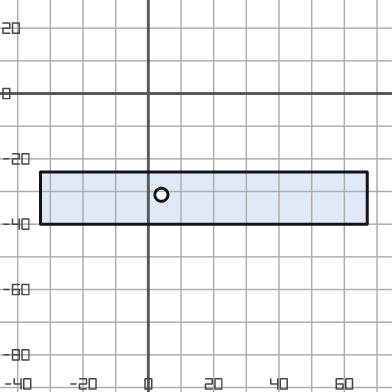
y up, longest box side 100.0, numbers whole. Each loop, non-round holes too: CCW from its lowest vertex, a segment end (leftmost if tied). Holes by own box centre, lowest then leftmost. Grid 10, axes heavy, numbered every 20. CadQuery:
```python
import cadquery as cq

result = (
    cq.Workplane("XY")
    .moveTo(-33.0, -40.0)
    .lineTo(67.0, -40.0)
    .lineTo(67.0, -24.0)
    .lineTo(-33.0, -24.0)
    .close()
    .moveTo(4.0, -31.0)
    .circle(2.0)
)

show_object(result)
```